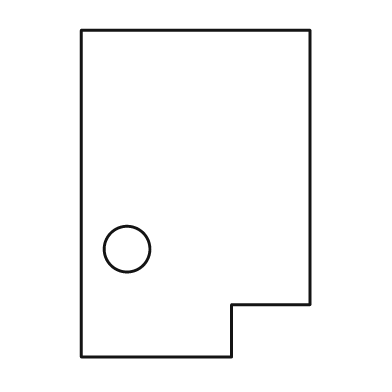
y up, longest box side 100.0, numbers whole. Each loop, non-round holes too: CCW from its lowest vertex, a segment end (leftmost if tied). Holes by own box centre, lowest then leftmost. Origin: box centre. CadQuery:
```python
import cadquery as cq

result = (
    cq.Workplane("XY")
    .moveTo(-35.0, -50.0)
    .lineTo(11.0, -50.0)
    .lineTo(11.0, -34.0)
    .lineTo(35.0, -34.0)
    .lineTo(35.0, 50.0)
    .lineTo(-35.0, 50.0)
    .close()
    .moveTo(-21.0, -17.0)
    .circle(7.0)
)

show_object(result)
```